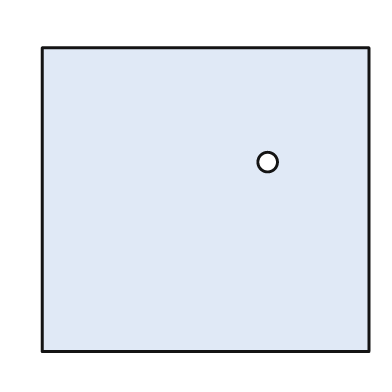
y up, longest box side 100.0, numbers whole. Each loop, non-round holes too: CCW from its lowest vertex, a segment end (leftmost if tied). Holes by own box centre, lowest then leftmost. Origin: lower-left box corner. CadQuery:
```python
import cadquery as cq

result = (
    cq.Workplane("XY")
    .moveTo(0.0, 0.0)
    .lineTo(100.0, 0.0)
    .lineTo(100.0, 93.0)
    .lineTo(0.0, 93.0)
    .close()
    .moveTo(69.0, 58.0)
    .circle(3.0)
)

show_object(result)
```